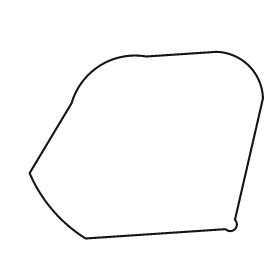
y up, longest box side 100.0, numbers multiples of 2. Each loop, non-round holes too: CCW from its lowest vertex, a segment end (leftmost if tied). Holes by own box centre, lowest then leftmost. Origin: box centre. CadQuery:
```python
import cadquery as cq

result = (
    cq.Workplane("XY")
    .moveTo(-26.0, -40.0)
    .lineTo(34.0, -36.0)
    .threePointArc((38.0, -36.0), (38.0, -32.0))
    .lineTo(50.0, 20.0)
    .threePointArc((44.0, 34.0), (30.0, 40.0))
    .lineTo(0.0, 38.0)
    .threePointArc((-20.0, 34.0), (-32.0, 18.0))
    .lineTo(-50.0, -12.0)
    .threePointArc((-40.0, -28.0), (-26.0, -40.0))
    .close()
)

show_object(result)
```